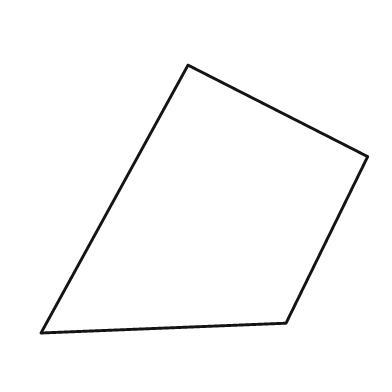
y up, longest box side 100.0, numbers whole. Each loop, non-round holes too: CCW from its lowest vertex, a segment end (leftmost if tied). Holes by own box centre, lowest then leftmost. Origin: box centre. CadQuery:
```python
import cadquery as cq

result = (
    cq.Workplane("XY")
    .moveTo(-50.0, -41.0)
    .lineTo(25.0, -38.0)
    .lineTo(50.0, 13.0)
    .lineTo(-5.0, 41.0)
    .close()
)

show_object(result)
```